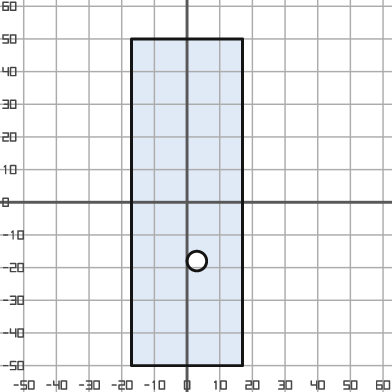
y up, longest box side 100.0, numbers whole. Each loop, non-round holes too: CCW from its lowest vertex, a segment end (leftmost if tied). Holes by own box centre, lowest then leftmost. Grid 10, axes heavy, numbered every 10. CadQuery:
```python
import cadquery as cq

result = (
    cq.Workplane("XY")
    .moveTo(-17.0, -50.0)
    .lineTo(17.0, -50.0)
    .lineTo(17.0, 50.0)
    .lineTo(-17.0, 50.0)
    .close()
    .moveTo(3.0, -18.0)
    .circle(3.0)
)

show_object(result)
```